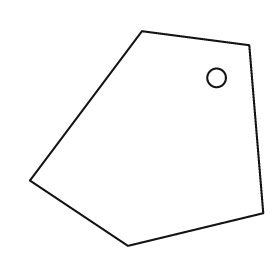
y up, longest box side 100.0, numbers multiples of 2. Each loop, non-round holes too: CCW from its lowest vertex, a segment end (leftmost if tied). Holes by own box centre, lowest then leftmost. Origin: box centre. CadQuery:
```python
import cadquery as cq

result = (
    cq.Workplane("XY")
    .moveTo(-8.0, -46.0)
    .lineTo(50.0, -32.0)
    .lineTo(44.0, 40.0)
    .lineTo(-2.0, 46.0)
    .lineTo(-50.0, -18.0)
    .close()
    .moveTo(30.0, 26.0)
    .circle(4.0)
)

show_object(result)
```